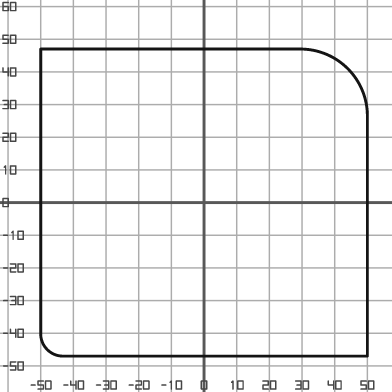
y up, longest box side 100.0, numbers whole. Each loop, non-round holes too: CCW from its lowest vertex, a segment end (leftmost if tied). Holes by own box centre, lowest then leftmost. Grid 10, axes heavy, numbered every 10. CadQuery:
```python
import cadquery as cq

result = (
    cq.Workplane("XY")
    .moveTo(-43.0, -47.0)
    .lineTo(50.0, -47.0)
    .lineTo(50.0, 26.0)
    .threePointArc((44.0, 41.0), (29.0, 47.0))
    .lineTo(-50.0, 47.0)
    .lineTo(-50.0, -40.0)
    .threePointArc((-48.0, -45.0), (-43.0, -47.0))
    .close()
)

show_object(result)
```